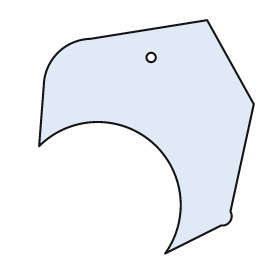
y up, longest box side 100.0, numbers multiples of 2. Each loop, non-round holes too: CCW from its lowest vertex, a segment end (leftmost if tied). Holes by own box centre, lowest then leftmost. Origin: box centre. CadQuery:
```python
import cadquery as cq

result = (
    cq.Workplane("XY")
    .moveTo(8.0, -50.0)
    .lineTo(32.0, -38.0)
    .threePointArc((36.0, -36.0), (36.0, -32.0))
    .lineTo(46.0, 14.0)
    .lineTo(26.0, 50.0)
    .lineTo(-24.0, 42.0)
    .threePointArc((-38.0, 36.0), (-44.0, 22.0))
    .lineTo(-46.0, -4.0)
    .threePointArc((2.0, -2.0), (8.0, -50.0))
    .close()
    .moveTo(2.0, 34.0)
    .circle(2.0)
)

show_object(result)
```